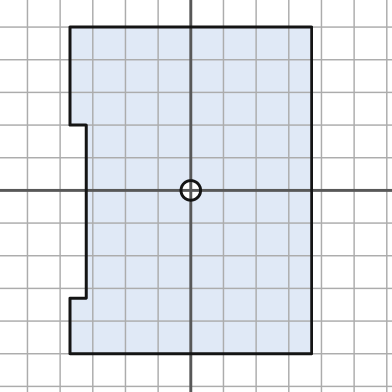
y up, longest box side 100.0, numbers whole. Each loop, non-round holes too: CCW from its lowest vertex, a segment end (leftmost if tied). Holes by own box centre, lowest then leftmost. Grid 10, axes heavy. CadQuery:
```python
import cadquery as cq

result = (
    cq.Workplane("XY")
    .moveTo(-37.0, -50.0)
    .lineTo(37.0, -50.0)
    .lineTo(37.0, 50.0)
    .lineTo(-37.0, 50.0)
    .lineTo(-37.0, 20.0)
    .lineTo(-32.0, 20.0)
    .lineTo(-32.0, -33.0)
    .lineTo(-37.0, -33.0)
    .close()
    .moveTo(0.0, 0.0)
    .circle(3.0)
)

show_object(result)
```